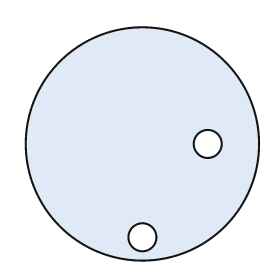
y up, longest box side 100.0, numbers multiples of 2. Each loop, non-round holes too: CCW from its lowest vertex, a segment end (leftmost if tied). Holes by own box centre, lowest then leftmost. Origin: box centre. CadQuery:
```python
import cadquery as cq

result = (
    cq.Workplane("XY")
    .moveTo(0.0, 0.0)
    .circle(50.0)
    .moveTo(0.0, -40.0)
    .circle(6.0)
    .moveTo(28.0, 0.0)
    .circle(6.0)
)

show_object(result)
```